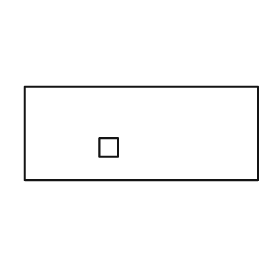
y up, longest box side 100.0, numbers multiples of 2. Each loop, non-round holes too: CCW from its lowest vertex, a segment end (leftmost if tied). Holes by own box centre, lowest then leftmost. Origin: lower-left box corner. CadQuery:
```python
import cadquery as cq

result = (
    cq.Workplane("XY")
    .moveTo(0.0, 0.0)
    .lineTo(100.0, 0.0)
    .lineTo(100.0, 40.0)
    .lineTo(0.0, 40.0)
    .close()
    .moveTo(32.0, 10.0)
    .lineTo(40.0, 10.0)
    .lineTo(40.0, 18.0)
    .lineTo(32.0, 18.0)
    .close()
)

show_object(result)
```